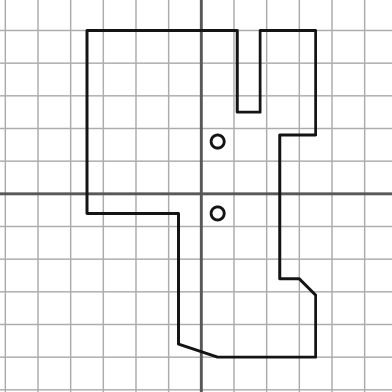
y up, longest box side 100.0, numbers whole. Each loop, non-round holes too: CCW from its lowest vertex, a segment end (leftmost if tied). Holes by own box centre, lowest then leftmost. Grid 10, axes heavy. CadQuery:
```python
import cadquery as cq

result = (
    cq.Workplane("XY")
    .moveTo(5.0, -50.0)
    .lineTo(35.0, -50.0)
    .lineTo(35.0, -31.0)
    .lineTo(30.0, -26.0)
    .lineTo(24.0, -26.0)
    .lineTo(24.0, 18.0)
    .lineTo(35.0, 18.0)
    .lineTo(35.0, 50.0)
    .lineTo(18.0, 50.0)
    .lineTo(18.0, 25.0)
    .lineTo(11.0, 25.0)
    .lineTo(11.0, 50.0)
    .lineTo(-35.0, 50.0)
    .lineTo(-35.0, -6.0)
    .lineTo(-7.0, -6.0)
    .lineTo(-7.0, -46.0)
    .close()
    .moveTo(5.0, -6.0)
    .circle(2.0)
    .moveTo(5.0, 16.0)
    .circle(2.0)
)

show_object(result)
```